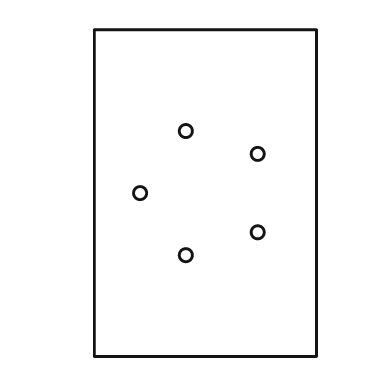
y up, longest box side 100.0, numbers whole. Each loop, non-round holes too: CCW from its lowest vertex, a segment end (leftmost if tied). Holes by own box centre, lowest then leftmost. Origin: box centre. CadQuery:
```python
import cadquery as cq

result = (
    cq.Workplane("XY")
    .moveTo(-34.0, -50.0)
    .lineTo(34.0, -50.0)
    .lineTo(34.0, 50.0)
    .lineTo(-34.0, 50.0)
    .close()
    .moveTo(-6.0, -19.0)
    .circle(2.0)
    .moveTo(16.0, -12.0)
    .circle(2.0)
    .moveTo(-20.0, 0.0)
    .circle(2.0)
    .moveTo(16.0, 12.0)
    .circle(2.0)
    .moveTo(-6.0, 19.0)
    .circle(2.0)
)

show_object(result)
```